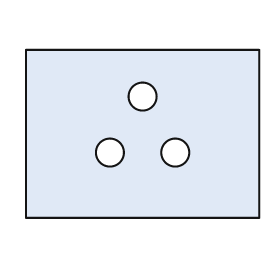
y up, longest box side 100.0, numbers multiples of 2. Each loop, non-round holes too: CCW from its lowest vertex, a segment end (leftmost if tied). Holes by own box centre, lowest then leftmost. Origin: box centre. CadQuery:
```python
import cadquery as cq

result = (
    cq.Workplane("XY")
    .moveTo(-50.0, -36.0)
    .lineTo(50.0, -36.0)
    .lineTo(50.0, 36.0)
    .lineTo(-50.0, 36.0)
    .close()
    .moveTo(-14.0, -8.0)
    .circle(6.0)
    .moveTo(14.0, -8.0)
    .circle(6.0)
    .moveTo(0.0, 16.0)
    .circle(6.0)
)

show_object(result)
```